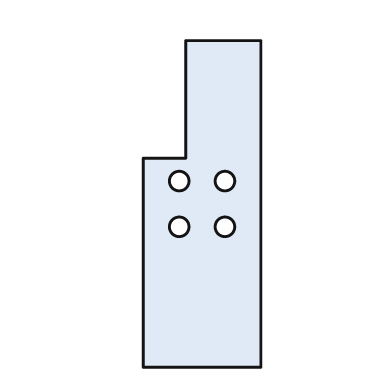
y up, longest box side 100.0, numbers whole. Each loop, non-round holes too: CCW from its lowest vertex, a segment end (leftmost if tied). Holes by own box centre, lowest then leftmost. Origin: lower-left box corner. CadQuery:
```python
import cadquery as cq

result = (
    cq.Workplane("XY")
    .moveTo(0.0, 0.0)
    .lineTo(36.0, 0.0)
    .lineTo(36.0, 100.0)
    .lineTo(13.0, 100.0)
    .lineTo(13.0, 64.0)
    .lineTo(0.0, 64.0)
    .close()
    .moveTo(11.0, 43.0)
    .circle(3.0)
    .moveTo(25.0, 43.0)
    .circle(3.0)
    .moveTo(11.0, 57.0)
    .circle(3.0)
    .moveTo(25.0, 57.0)
    .circle(3.0)
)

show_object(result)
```